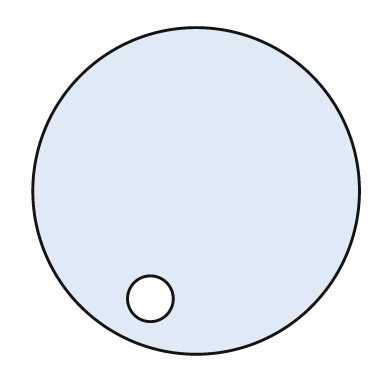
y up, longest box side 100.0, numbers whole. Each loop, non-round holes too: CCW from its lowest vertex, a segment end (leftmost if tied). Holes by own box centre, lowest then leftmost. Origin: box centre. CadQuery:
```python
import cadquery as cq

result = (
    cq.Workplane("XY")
    .moveTo(0.0, 0.0)
    .circle(50.0)
    .moveTo(-14.0, -33.0)
    .circle(7.0)
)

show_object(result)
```